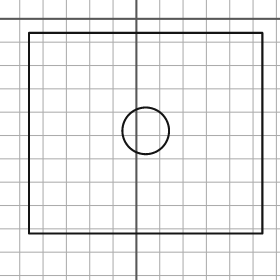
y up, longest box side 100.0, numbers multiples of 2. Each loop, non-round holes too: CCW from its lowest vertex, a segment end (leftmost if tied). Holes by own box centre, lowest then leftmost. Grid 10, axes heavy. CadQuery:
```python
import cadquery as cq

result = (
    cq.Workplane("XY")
    .moveTo(-46.0, -92.0)
    .lineTo(54.0, -92.0)
    .lineTo(54.0, -6.0)
    .lineTo(-46.0, -6.0)
    .close()
    .moveTo(4.0, -48.0)
    .circle(10.0)
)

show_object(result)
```